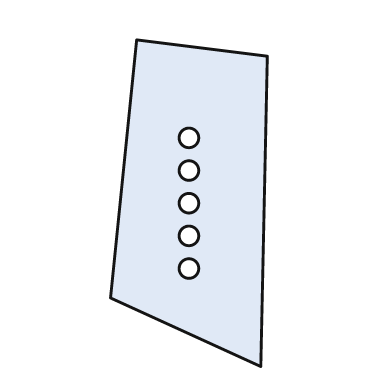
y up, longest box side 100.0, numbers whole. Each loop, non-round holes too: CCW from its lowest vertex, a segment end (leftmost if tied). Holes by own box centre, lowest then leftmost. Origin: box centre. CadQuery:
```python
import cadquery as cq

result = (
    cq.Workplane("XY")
    .moveTo(22.0, -50.0)
    .lineTo(24.0, 45.0)
    .lineTo(-16.0, 50.0)
    .lineTo(-24.0, -29.0)
    .close()
    .moveTo(0.0, -20.0)
    .circle(3.0)
    .moveTo(0.0, -10.0)
    .circle(3.0)
    .moveTo(0.0, 0.0)
    .circle(3.0)
    .moveTo(0.0, 10.0)
    .circle(3.0)
    .moveTo(0.0, 20.0)
    .circle(3.0)
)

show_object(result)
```